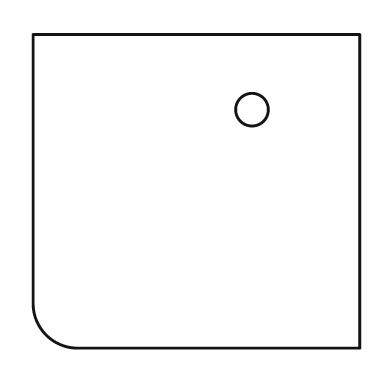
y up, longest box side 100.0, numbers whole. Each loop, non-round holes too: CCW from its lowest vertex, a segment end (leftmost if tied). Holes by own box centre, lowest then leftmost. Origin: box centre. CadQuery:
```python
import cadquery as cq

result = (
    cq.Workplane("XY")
    .moveTo(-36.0, -48.0)
    .lineTo(50.0, -48.0)
    .lineTo(50.0, 48.0)
    .lineTo(-50.0, 48.0)
    .lineTo(-50.0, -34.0)
    .threePointArc((-46.0, -44.0), (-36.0, -48.0))
    .close()
    .moveTo(17.0, 25.0)
    .circle(5.0)
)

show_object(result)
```